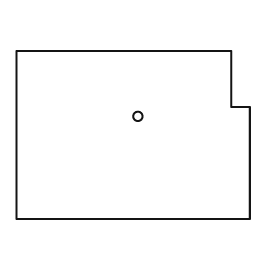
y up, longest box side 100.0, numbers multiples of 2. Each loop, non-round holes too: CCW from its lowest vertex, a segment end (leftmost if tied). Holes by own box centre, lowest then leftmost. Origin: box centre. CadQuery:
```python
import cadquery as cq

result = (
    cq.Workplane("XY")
    .moveTo(-50.0, -36.0)
    .lineTo(50.0, -36.0)
    .lineTo(50.0, 12.0)
    .lineTo(42.0, 12.0)
    .lineTo(42.0, 36.0)
    .lineTo(-50.0, 36.0)
    .close()
    .moveTo(2.0, 8.0)
    .circle(2.0)
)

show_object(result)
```